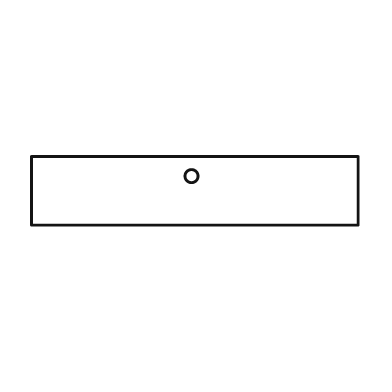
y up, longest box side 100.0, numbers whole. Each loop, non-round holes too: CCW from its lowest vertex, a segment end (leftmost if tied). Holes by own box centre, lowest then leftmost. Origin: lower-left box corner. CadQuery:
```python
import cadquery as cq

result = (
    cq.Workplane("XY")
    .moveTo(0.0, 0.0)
    .lineTo(100.0, 0.0)
    .lineTo(100.0, 21.0)
    .lineTo(0.0, 21.0)
    .close()
    .moveTo(49.0, 15.0)
    .circle(2.0)
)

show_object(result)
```